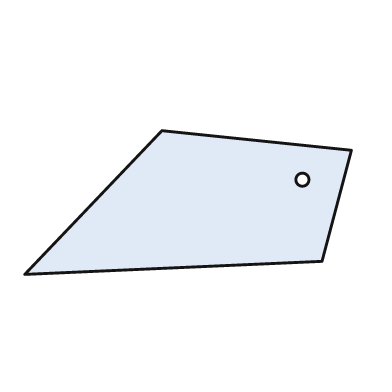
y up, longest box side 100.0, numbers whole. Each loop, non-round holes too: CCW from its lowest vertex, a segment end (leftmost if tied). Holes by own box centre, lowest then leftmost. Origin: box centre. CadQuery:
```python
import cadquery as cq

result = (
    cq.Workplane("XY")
    .moveTo(-50.0, -22.0)
    .lineTo(41.0, -18.0)
    .lineTo(50.0, 16.0)
    .lineTo(-8.0, 22.0)
    .close()
    .moveTo(35.0, 7.0)
    .circle(2.0)
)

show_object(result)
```